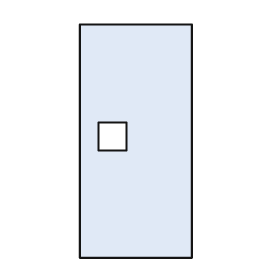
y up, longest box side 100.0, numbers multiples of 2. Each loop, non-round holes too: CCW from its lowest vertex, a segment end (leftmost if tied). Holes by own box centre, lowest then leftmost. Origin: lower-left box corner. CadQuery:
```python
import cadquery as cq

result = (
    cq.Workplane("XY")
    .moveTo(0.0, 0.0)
    .lineTo(48.0, 0.0)
    .lineTo(48.0, 100.0)
    .lineTo(0.0, 100.0)
    .close()
    .moveTo(8.0, 46.0)
    .lineTo(20.0, 46.0)
    .lineTo(20.0, 58.0)
    .lineTo(8.0, 58.0)
    .close()
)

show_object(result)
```